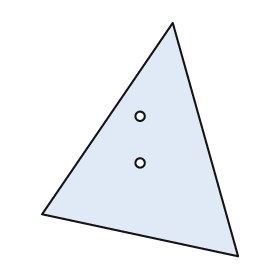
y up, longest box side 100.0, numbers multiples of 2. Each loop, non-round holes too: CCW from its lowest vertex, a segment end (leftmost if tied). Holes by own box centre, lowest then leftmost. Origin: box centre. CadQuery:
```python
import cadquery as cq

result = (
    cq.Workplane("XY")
    .moveTo(42.0, -50.0)
    .lineTo(14.0, 50.0)
    .lineTo(-42.0, -32.0)
    .close()
    .moveTo(0.0, -10.0)
    .circle(2.0)
    .moveTo(0.0, 10.0)
    .circle(2.0)
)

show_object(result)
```